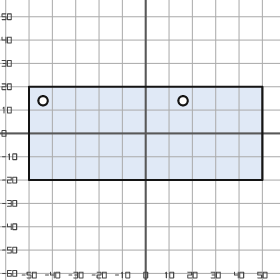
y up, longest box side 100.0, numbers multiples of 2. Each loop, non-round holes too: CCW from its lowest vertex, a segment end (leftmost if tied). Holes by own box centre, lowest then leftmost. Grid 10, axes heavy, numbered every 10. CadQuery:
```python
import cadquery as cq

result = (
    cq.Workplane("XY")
    .moveTo(-50.0, -20.0)
    .lineTo(50.0, -20.0)
    .lineTo(50.0, 20.0)
    .lineTo(-50.0, 20.0)
    .close()
    .moveTo(-44.0, 14.0)
    .circle(2.0)
    .moveTo(16.0, 14.0)
    .circle(2.0)
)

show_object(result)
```